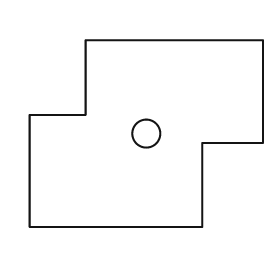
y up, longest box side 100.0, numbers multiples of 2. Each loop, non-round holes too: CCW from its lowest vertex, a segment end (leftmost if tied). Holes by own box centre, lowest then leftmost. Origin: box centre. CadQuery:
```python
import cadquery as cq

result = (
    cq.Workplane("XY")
    .moveTo(-50.0, -40.0)
    .lineTo(24.0, -40.0)
    .lineTo(24.0, -4.0)
    .lineTo(50.0, -4.0)
    .lineTo(50.0, 40.0)
    .lineTo(-26.0, 40.0)
    .lineTo(-26.0, 8.0)
    .lineTo(-50.0, 8.0)
    .close()
    .moveTo(0.0, 0.0)
    .circle(6.0)
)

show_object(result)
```